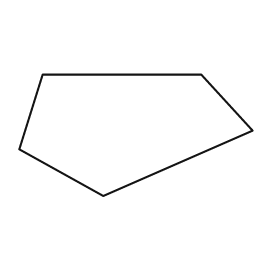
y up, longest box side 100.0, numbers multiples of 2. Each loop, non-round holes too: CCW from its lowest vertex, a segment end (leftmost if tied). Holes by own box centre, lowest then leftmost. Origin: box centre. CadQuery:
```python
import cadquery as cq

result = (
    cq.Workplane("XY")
    .moveTo(-14.0, -26.0)
    .lineTo(50.0, 2.0)
    .lineTo(28.0, 26.0)
    .lineTo(-40.0, 26.0)
    .lineTo(-50.0, -6.0)
    .close()
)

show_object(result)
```